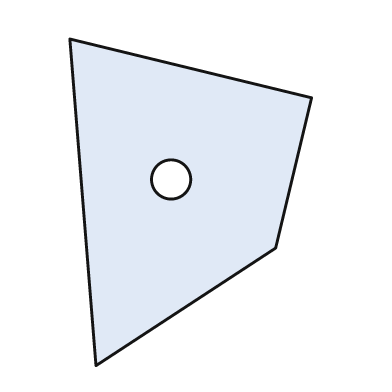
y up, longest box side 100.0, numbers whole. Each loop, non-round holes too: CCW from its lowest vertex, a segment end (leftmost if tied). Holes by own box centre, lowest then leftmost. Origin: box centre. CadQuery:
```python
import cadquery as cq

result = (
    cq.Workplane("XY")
    .moveTo(-29.0, -50.0)
    .lineTo(26.0, -14.0)
    .lineTo(37.0, 32.0)
    .lineTo(-37.0, 50.0)
    .close()
    .moveTo(-6.0, 7.0)
    .circle(6.0)
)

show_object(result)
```